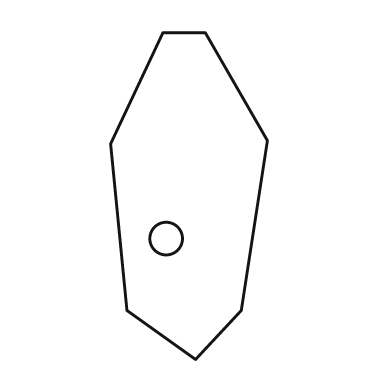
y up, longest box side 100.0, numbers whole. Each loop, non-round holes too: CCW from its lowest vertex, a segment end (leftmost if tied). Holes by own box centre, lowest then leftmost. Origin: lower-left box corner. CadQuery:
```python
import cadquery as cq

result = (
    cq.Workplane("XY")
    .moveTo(26.0, 0.0)
    .lineTo(40.0, 15.0)
    .lineTo(48.0, 67.0)
    .lineTo(29.0, 100.0)
    .lineTo(16.0, 100.0)
    .lineTo(0.0, 66.0)
    .lineTo(5.0, 15.0)
    .close()
    .moveTo(17.0, 37.0)
    .circle(5.0)
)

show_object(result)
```